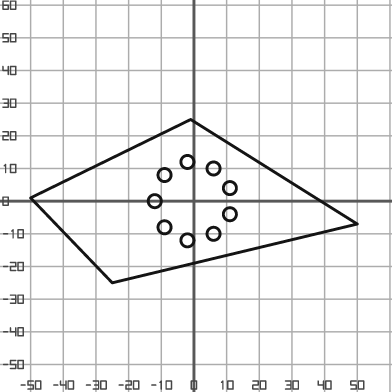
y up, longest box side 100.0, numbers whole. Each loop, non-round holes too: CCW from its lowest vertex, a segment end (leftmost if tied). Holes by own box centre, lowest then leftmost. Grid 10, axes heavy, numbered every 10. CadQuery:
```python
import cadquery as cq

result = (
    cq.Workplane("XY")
    .moveTo(-25.0, -25.0)
    .lineTo(50.0, -7.0)
    .lineTo(-1.0, 25.0)
    .lineTo(-50.0, 1.0)
    .close()
    .moveTo(-2.0, -12.0)
    .circle(2.0)
    .moveTo(6.0, -10.0)
    .circle(2.0)
    .moveTo(-9.0, -8.0)
    .circle(2.0)
    .moveTo(11.0, -4.0)
    .circle(2.0)
    .moveTo(-12.0, 0.0)
    .circle(2.0)
    .moveTo(11.0, 4.0)
    .circle(2.0)
    .moveTo(-9.0, 8.0)
    .circle(2.0)
    .moveTo(6.0, 10.0)
    .circle(2.0)
    .moveTo(-2.0, 12.0)
    .circle(2.0)
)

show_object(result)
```